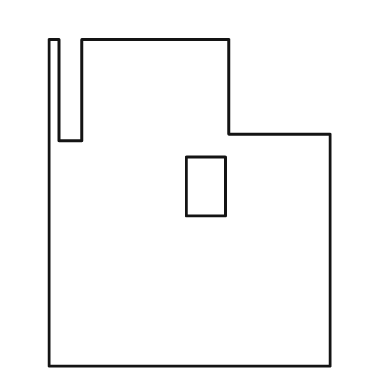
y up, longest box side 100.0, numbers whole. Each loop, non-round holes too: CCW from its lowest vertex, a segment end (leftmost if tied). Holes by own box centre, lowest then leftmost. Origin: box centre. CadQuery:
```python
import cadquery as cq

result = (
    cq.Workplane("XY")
    .moveTo(-43.0, -50.0)
    .lineTo(43.0, -50.0)
    .lineTo(43.0, 21.0)
    .lineTo(12.0, 21.0)
    .lineTo(12.0, 50.0)
    .lineTo(-33.0, 50.0)
    .lineTo(-33.0, 19.0)
    .lineTo(-40.0, 19.0)
    .lineTo(-40.0, 50.0)
    .lineTo(-43.0, 50.0)
    .close()
    .moveTo(-1.0, -4.0)
    .lineTo(11.0, -4.0)
    .lineTo(11.0, 14.0)
    .lineTo(-1.0, 14.0)
    .close()
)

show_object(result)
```